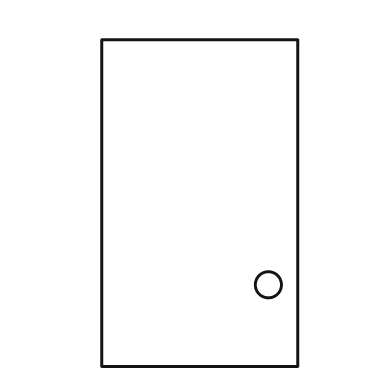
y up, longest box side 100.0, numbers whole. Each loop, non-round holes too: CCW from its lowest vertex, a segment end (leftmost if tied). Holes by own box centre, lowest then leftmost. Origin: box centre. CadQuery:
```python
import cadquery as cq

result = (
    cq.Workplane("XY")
    .moveTo(-30.0, -50.0)
    .lineTo(30.0, -50.0)
    .lineTo(30.0, 50.0)
    .lineTo(-30.0, 50.0)
    .close()
    .moveTo(21.0, -25.0)
    .circle(4.0)
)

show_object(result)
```